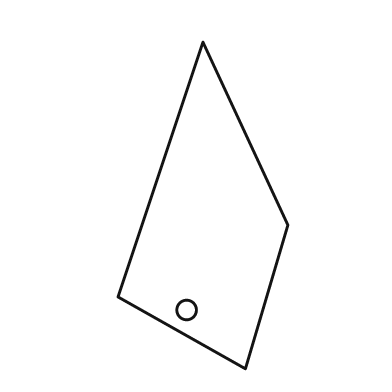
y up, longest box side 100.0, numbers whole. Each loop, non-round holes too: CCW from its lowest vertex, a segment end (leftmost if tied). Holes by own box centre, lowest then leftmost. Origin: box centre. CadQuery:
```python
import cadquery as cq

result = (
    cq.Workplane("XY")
    .moveTo(13.0, -50.0)
    .lineTo(26.0, -6.0)
    .lineTo(0.0, 50.0)
    .lineTo(-26.0, -28.0)
    .close()
    .moveTo(-5.0, -32.0)
    .circle(3.0)
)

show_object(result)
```